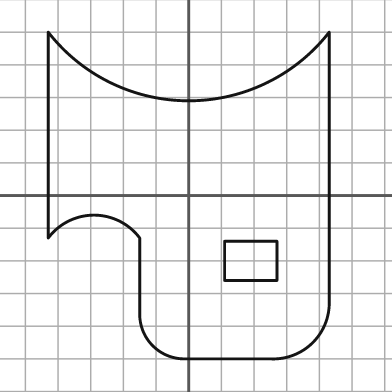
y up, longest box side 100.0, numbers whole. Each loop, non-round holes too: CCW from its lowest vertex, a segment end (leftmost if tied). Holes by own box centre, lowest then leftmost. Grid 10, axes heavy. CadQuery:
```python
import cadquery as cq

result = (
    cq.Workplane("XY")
    .moveTo(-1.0, -50.0)
    .lineTo(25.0, -50.0)
    .threePointArc((38.0, -45.0), (43.0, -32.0))
    .lineTo(43.0, 50.0)
    .threePointArc((0.0, 29.0), (-43.0, 50.0))
    .lineTo(-43.0, -13.0)
    .threePointArc((-29.0, -6.0), (-15.0, -13.0))
    .lineTo(-15.0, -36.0)
    .threePointArc((-11.0, -46.0), (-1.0, -50.0))
    .close()
    .moveTo(11.0, -26.0)
    .lineTo(27.0, -26.0)
    .lineTo(27.0, -14.0)
    .lineTo(11.0, -14.0)
    .close()
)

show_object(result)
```